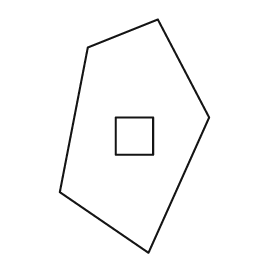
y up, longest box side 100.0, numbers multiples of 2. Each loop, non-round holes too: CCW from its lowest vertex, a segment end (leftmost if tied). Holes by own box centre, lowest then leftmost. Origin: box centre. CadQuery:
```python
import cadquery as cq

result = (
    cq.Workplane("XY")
    .moveTo(6.0, -50.0)
    .lineTo(32.0, 8.0)
    .lineTo(10.0, 50.0)
    .lineTo(-20.0, 38.0)
    .lineTo(-32.0, -24.0)
    .close()
    .moveTo(-8.0, -8.0)
    .lineTo(8.0, -8.0)
    .lineTo(8.0, 8.0)
    .lineTo(-8.0, 8.0)
    .close()
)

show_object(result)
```